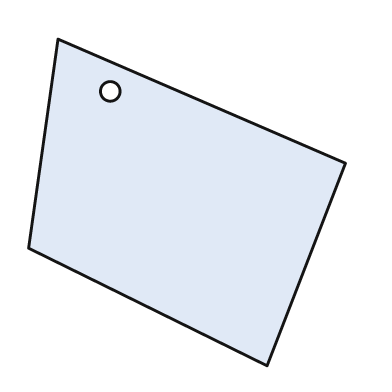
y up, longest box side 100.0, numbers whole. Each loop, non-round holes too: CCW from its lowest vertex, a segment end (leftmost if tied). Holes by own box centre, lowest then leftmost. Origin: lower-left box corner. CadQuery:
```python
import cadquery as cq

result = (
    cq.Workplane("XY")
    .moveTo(73.0, 0.0)
    .lineTo(97.0, 62.0)
    .lineTo(9.0, 100.0)
    .lineTo(0.0, 36.0)
    .close()
    .moveTo(25.0, 84.0)
    .circle(3.0)
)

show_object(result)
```